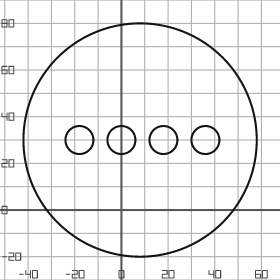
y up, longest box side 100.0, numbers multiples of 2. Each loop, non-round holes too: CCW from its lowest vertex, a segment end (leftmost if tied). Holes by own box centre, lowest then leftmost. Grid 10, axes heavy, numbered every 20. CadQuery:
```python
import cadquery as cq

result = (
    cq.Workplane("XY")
    .moveTo(8.0, 30.0)
    .circle(50.0)
    .moveTo(-18.0, 30.0)
    .circle(6.0)
    .moveTo(0.0, 30.0)
    .circle(6.0)
    .moveTo(18.0, 30.0)
    .circle(6.0)
    .moveTo(36.0, 30.0)
    .circle(6.0)
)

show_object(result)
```